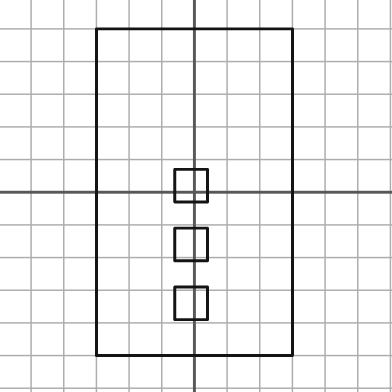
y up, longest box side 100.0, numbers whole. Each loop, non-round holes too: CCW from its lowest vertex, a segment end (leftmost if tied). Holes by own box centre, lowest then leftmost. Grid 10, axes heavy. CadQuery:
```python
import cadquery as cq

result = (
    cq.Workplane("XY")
    .moveTo(-30.0, -50.0)
    .lineTo(30.0, -50.0)
    .lineTo(30.0, 50.0)
    .lineTo(-30.0, 50.0)
    .close()
    .moveTo(-6.0, -39.0)
    .lineTo(4.0, -39.0)
    .lineTo(4.0, -29.0)
    .lineTo(-6.0, -29.0)
    .close()
    .moveTo(-6.0, -21.0)
    .lineTo(4.0, -21.0)
    .lineTo(4.0, -11.0)
    .lineTo(-6.0, -11.0)
    .close()
    .moveTo(-6.0, -3.0)
    .lineTo(4.0, -3.0)
    .lineTo(4.0, 7.0)
    .lineTo(-6.0, 7.0)
    .close()
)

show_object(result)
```